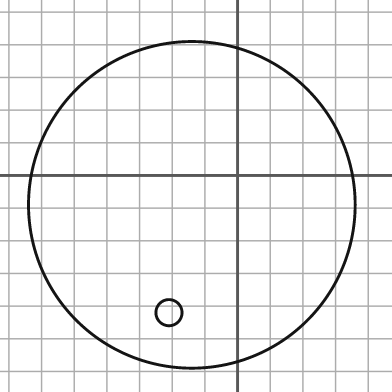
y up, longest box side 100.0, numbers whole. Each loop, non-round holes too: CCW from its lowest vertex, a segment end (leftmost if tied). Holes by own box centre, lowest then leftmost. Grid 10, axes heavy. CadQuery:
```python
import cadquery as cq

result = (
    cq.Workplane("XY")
    .moveTo(-14.0, -9.0)
    .circle(50.0)
    .moveTo(-21.0, -42.0)
    .circle(4.0)
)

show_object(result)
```